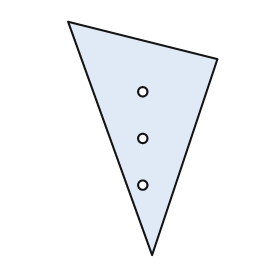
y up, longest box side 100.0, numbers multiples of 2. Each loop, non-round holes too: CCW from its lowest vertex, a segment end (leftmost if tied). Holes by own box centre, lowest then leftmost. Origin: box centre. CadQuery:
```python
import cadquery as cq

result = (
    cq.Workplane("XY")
    .moveTo(4.0, -50.0)
    .lineTo(32.0, 34.0)
    .lineTo(-32.0, 50.0)
    .close()
    .moveTo(0.0, -20.0)
    .circle(2.0)
    .moveTo(0.0, 0.0)
    .circle(2.0)
    .moveTo(0.0, 20.0)
    .circle(2.0)
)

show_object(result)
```